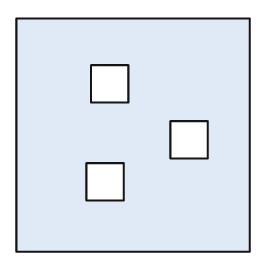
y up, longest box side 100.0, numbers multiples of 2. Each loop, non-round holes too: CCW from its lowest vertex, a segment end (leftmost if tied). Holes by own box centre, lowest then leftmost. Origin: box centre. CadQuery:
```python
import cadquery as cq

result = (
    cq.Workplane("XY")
    .moveTo(-50.0, -50.0)
    .lineTo(50.0, -50.0)
    .lineTo(50.0, 50.0)
    .lineTo(-50.0, 50.0)
    .close()
    .moveTo(-20.0, -28.0)
    .lineTo(-4.0, -28.0)
    .lineTo(-4.0, -12.0)
    .lineTo(-20.0, -12.0)
    .close()
    .moveTo(16.0, -10.0)
    .lineTo(32.0, -10.0)
    .lineTo(32.0, 6.0)
    .lineTo(16.0, 6.0)
    .close()
    .moveTo(-18.0, 14.0)
    .lineTo(-2.0, 14.0)
    .lineTo(-2.0, 30.0)
    .lineTo(-18.0, 30.0)
    .close()
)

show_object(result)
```